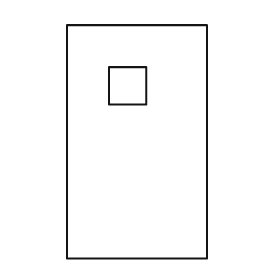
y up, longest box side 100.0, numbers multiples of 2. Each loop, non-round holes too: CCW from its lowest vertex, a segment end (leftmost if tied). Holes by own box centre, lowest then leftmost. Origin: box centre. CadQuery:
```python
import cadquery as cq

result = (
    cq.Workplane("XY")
    .moveTo(-30.0, -50.0)
    .lineTo(30.0, -50.0)
    .lineTo(30.0, 50.0)
    .lineTo(-30.0, 50.0)
    .close()
    .moveTo(-12.0, 16.0)
    .lineTo(4.0, 16.0)
    .lineTo(4.0, 32.0)
    .lineTo(-12.0, 32.0)
    .close()
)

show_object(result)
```